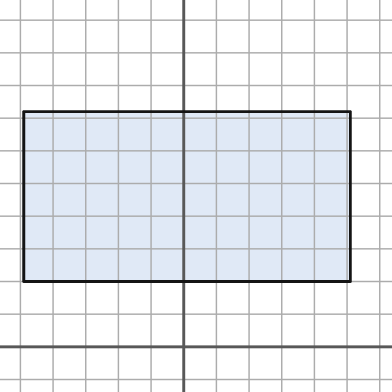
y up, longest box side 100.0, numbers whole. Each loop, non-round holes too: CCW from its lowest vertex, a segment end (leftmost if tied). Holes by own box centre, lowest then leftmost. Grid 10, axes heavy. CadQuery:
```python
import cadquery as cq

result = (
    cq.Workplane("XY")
    .moveTo(-49.0, 20.0)
    .lineTo(51.0, 20.0)
    .lineTo(51.0, 72.0)
    .lineTo(-49.0, 72.0)
    .close()
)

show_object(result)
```